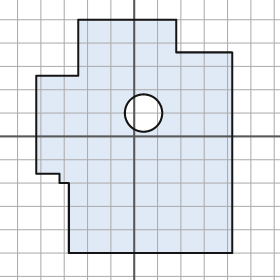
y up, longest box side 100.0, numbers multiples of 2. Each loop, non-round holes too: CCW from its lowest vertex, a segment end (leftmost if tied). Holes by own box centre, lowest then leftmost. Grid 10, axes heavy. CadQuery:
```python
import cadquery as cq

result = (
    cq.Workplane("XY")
    .moveTo(-28.0, -50.0)
    .lineTo(42.0, -50.0)
    .lineTo(42.0, 36.0)
    .lineTo(18.0, 36.0)
    .lineTo(18.0, 50.0)
    .lineTo(-24.0, 50.0)
    .lineTo(-24.0, 26.0)
    .lineTo(-42.0, 26.0)
    .lineTo(-42.0, -16.0)
    .lineTo(-32.0, -16.0)
    .lineTo(-32.0, -20.0)
    .lineTo(-28.0, -20.0)
    .close()
    .moveTo(4.0, 10.0)
    .circle(8.0)
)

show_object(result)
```